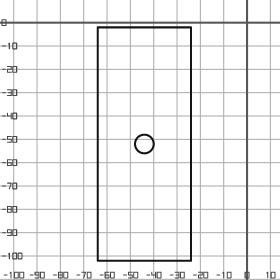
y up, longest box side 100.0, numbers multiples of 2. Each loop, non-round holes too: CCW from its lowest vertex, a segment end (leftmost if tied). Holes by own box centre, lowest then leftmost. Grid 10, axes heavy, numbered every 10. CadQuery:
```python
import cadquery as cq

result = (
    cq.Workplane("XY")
    .moveTo(-64.0, -102.0)
    .lineTo(-24.0, -102.0)
    .lineTo(-24.0, -2.0)
    .lineTo(-64.0, -2.0)
    .close()
    .moveTo(-44.0, -52.0)
    .circle(4.0)
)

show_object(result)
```